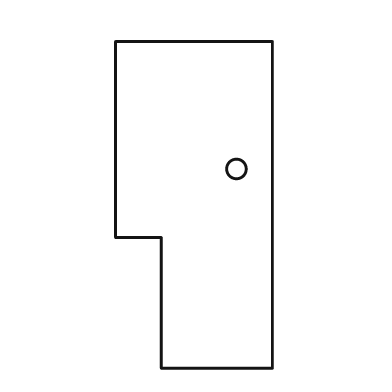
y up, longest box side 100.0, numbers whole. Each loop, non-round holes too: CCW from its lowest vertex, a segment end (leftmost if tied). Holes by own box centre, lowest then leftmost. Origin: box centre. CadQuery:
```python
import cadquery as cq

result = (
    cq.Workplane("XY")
    .moveTo(-10.0, -50.0)
    .lineTo(24.0, -50.0)
    .lineTo(24.0, 50.0)
    .lineTo(-24.0, 50.0)
    .lineTo(-24.0, -10.0)
    .lineTo(-10.0, -10.0)
    .close()
    .moveTo(13.0, 11.0)
    .circle(3.0)
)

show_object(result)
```